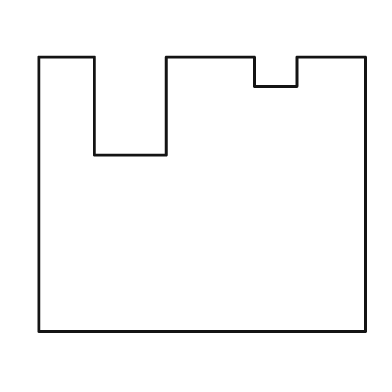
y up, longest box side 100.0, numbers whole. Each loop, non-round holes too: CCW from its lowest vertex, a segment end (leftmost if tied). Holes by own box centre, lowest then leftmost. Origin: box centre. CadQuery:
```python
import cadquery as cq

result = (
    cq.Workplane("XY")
    .moveTo(-50.0, -42.0)
    .lineTo(50.0, -42.0)
    .lineTo(50.0, 42.0)
    .lineTo(29.0, 42.0)
    .lineTo(29.0, 33.0)
    .lineTo(16.0, 33.0)
    .lineTo(16.0, 42.0)
    .lineTo(-11.0, 42.0)
    .lineTo(-11.0, 12.0)
    .lineTo(-33.0, 12.0)
    .lineTo(-33.0, 42.0)
    .lineTo(-50.0, 42.0)
    .close()
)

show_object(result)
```